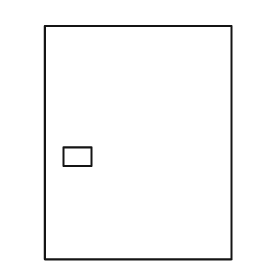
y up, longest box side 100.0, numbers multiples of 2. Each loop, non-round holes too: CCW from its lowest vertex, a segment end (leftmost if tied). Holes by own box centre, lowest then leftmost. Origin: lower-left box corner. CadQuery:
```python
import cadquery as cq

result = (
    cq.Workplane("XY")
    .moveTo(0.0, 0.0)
    .lineTo(80.0, 0.0)
    .lineTo(80.0, 100.0)
    .lineTo(0.0, 100.0)
    .close()
    .moveTo(8.0, 40.0)
    .lineTo(20.0, 40.0)
    .lineTo(20.0, 48.0)
    .lineTo(8.0, 48.0)
    .close()
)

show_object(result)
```